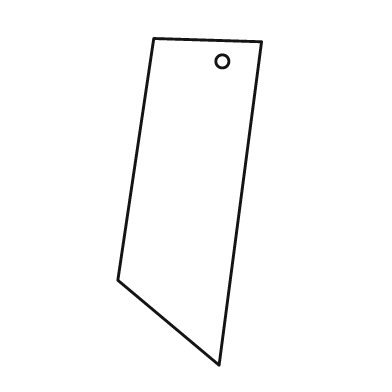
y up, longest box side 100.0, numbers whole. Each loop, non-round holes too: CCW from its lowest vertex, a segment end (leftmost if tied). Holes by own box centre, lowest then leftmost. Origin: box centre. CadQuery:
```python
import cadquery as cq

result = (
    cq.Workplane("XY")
    .moveTo(9.0, -50.0)
    .lineTo(22.0, 49.0)
    .lineTo(-11.0, 50.0)
    .lineTo(-22.0, -24.0)
    .close()
    .moveTo(10.0, 43.0)
    .circle(2.0)
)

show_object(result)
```